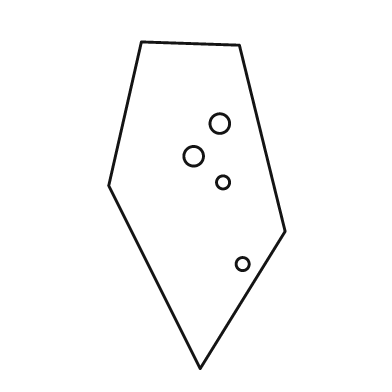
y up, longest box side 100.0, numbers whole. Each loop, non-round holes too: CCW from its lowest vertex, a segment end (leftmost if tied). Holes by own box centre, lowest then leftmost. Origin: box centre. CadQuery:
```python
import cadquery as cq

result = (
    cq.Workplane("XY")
    .moveTo(1.0, -50.0)
    .lineTo(27.0, -8.0)
    .lineTo(13.0, 49.0)
    .lineTo(-17.0, 50.0)
    .lineTo(-27.0, 6.0)
    .close()
    .moveTo(14.0, -18.0)
    .circle(2.0)
    .moveTo(8.0, 7.0)
    .circle(2.0)
    .moveTo(-1.0, 15.0)
    .circle(3.0)
    .moveTo(7.0, 25.0)
    .circle(3.0)
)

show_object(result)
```